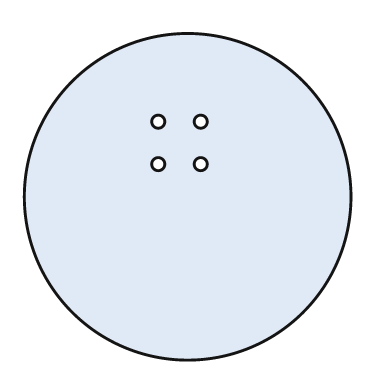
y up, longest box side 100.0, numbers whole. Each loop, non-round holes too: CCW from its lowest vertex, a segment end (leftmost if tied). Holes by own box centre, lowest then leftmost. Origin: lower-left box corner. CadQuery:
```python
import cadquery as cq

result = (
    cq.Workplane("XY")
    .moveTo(50.0, 50.0)
    .circle(50.0)
    .moveTo(41.0, 60.0)
    .circle(2.0)
    .moveTo(54.0, 60.0)
    .circle(2.0)
    .moveTo(41.0, 73.0)
    .circle(2.0)
    .moveTo(54.0, 73.0)
    .circle(2.0)
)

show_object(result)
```